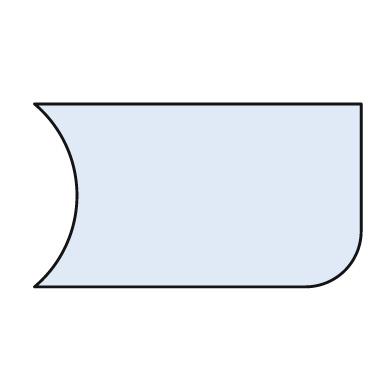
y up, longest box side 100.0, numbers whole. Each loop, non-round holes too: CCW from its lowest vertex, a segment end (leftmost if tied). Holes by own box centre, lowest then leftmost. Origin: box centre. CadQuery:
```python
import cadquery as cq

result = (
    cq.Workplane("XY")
    .moveTo(-50.0, -28.0)
    .lineTo(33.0, -28.0)
    .threePointArc((45.0, -23.0), (50.0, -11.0))
    .lineTo(50.0, 28.0)
    .lineTo(-50.0, 28.0)
    .threePointArc((-37.0, 0.0), (-50.0, -28.0))
    .close()
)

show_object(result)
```